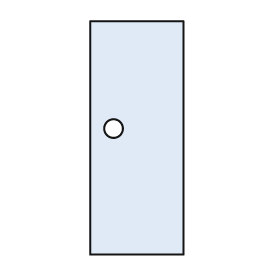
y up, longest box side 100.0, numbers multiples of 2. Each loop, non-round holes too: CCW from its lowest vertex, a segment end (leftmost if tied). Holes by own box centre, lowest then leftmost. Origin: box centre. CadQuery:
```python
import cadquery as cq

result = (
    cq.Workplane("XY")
    .moveTo(-20.0, -50.0)
    .lineTo(20.0, -50.0)
    .lineTo(20.0, 50.0)
    .lineTo(-20.0, 50.0)
    .close()
    .moveTo(-10.0, 4.0)
    .circle(4.0)
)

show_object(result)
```